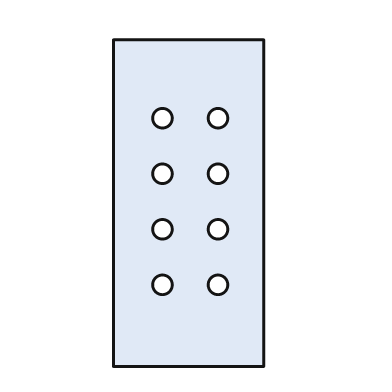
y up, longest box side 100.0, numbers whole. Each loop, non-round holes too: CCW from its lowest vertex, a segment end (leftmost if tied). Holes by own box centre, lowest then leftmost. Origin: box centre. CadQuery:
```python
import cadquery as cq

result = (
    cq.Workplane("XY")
    .moveTo(-23.0, -50.0)
    .lineTo(23.0, -50.0)
    .lineTo(23.0, 50.0)
    .lineTo(-23.0, 50.0)
    .close()
    .moveTo(-8.0, -25.0)
    .circle(3.0)
    .moveTo(9.0, -25.0)
    .circle(3.0)
    .moveTo(-8.0, -8.0)
    .circle(3.0)
    .moveTo(9.0, -8.0)
    .circle(3.0)
    .moveTo(-8.0, 9.0)
    .circle(3.0)
    .moveTo(9.0, 9.0)
    .circle(3.0)
    .moveTo(-8.0, 26.0)
    .circle(3.0)
    .moveTo(9.0, 26.0)
    .circle(3.0)
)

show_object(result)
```